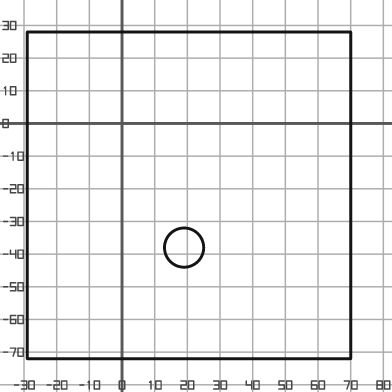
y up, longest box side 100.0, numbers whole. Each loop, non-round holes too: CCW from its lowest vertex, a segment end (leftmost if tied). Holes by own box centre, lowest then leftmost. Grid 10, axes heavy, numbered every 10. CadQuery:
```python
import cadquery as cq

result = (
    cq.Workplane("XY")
    .moveTo(-29.0, -72.0)
    .lineTo(70.0, -72.0)
    .lineTo(70.0, 28.0)
    .lineTo(-29.0, 28.0)
    .close()
    .moveTo(19.0, -38.0)
    .circle(6.0)
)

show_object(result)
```